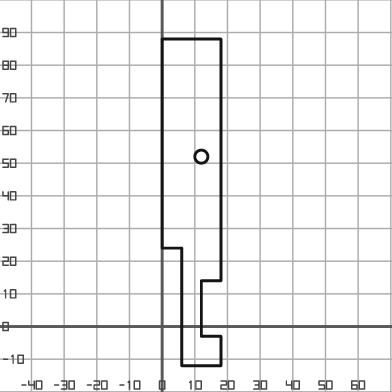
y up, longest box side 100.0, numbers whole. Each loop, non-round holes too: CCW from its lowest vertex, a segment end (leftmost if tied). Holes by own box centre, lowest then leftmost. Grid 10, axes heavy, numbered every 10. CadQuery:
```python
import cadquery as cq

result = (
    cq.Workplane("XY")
    .moveTo(6.0, -12.0)
    .lineTo(18.0, -12.0)
    .lineTo(18.0, -3.0)
    .lineTo(12.0, -3.0)
    .lineTo(12.0, 14.0)
    .lineTo(18.0, 14.0)
    .lineTo(18.0, 88.0)
    .lineTo(0.0, 88.0)
    .lineTo(0.0, 24.0)
    .lineTo(6.0, 24.0)
    .close()
    .moveTo(12.0, 52.0)
    .circle(2.0)
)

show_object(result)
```